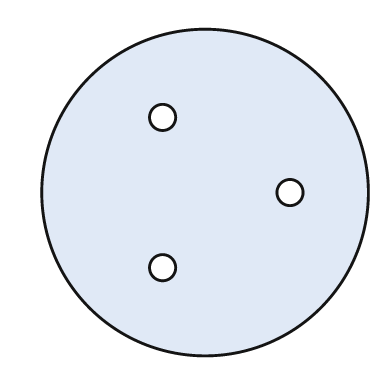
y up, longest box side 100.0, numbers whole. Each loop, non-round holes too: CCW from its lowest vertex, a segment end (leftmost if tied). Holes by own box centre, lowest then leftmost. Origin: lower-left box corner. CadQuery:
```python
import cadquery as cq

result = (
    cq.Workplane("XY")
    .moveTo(50.0, 50.0)
    .circle(50.0)
    .moveTo(37.0, 27.0)
    .circle(4.0)
    .moveTo(76.0, 50.0)
    .circle(4.0)
    .moveTo(37.0, 73.0)
    .circle(4.0)
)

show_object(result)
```